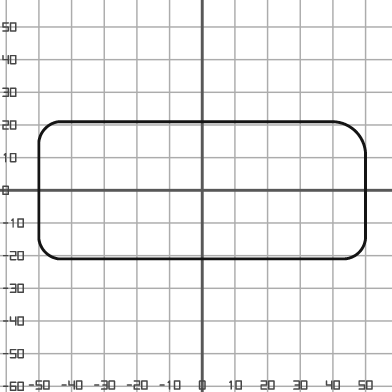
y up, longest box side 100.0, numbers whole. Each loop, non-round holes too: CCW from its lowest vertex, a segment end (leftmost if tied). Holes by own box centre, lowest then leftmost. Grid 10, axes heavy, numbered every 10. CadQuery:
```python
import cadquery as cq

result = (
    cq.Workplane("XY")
    .moveTo(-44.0, -21.0)
    .lineTo(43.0, -21.0)
    .threePointArc((48.0, -19.0), (50.0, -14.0))
    .lineTo(50.0, 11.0)
    .threePointArc((47.0, 18.0), (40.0, 21.0))
    .lineTo(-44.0, 21.0)
    .threePointArc((-48.0, 19.0), (-50.0, 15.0))
    .lineTo(-50.0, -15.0)
    .threePointArc((-48.0, -19.0), (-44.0, -21.0))
    .close()
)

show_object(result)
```